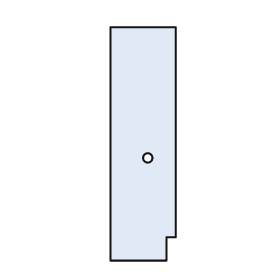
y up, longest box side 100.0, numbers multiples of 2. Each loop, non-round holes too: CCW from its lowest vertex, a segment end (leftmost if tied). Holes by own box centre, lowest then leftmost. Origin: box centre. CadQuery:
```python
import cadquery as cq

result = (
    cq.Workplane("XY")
    .moveTo(-14.0, -50.0)
    .lineTo(10.0, -50.0)
    .lineTo(10.0, -40.0)
    .lineTo(14.0, -40.0)
    .lineTo(14.0, 50.0)
    .lineTo(-14.0, 50.0)
    .close()
    .moveTo(2.0, -6.0)
    .circle(2.0)
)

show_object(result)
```